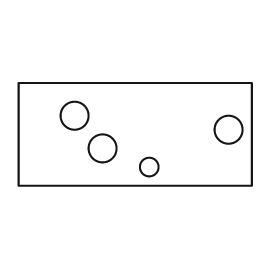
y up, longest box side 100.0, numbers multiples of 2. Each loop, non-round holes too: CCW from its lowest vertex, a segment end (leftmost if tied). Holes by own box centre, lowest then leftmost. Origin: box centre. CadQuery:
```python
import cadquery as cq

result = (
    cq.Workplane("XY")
    .moveTo(-50.0, -22.0)
    .lineTo(50.0, -22.0)
    .lineTo(50.0, 22.0)
    .lineTo(-50.0, 22.0)
    .close()
    .moveTo(6.0, -14.0)
    .circle(4.0)
    .moveTo(-14.0, -6.0)
    .circle(6.0)
    .moveTo(40.0, 2.0)
    .circle(6.0)
    .moveTo(-26.0, 8.0)
    .circle(6.0)
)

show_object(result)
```